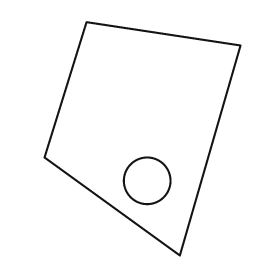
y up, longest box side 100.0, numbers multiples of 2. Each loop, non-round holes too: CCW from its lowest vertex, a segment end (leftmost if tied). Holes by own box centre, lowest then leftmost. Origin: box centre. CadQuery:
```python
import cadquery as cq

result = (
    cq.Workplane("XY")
    .moveTo(16.0, -50.0)
    .lineTo(42.0, 40.0)
    .lineTo(-24.0, 50.0)
    .lineTo(-42.0, -8.0)
    .close()
    .moveTo(2.0, -18.0)
    .circle(10.0)
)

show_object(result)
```